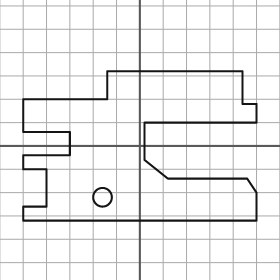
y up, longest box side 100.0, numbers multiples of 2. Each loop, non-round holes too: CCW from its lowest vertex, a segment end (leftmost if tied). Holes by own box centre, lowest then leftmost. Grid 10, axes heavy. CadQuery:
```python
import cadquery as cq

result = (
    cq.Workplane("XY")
    .moveTo(-50.0, -32.0)
    .lineTo(50.0, -32.0)
    .lineTo(50.0, -20.0)
    .lineTo(46.0, -14.0)
    .lineTo(12.0, -14.0)
    .lineTo(2.0, -6.0)
    .lineTo(2.0, 10.0)
    .lineTo(50.0, 10.0)
    .lineTo(50.0, 18.0)
    .lineTo(44.0, 18.0)
    .lineTo(44.0, 32.0)
    .lineTo(-14.0, 32.0)
    .lineTo(-14.0, 20.0)
    .lineTo(-50.0, 20.0)
    .lineTo(-50.0, 6.0)
    .lineTo(-30.0, 6.0)
    .lineTo(-30.0, -4.0)
    .lineTo(-50.0, -4.0)
    .lineTo(-50.0, -10.0)
    .lineTo(-40.0, -10.0)
    .lineTo(-40.0, -26.0)
    .lineTo(-50.0, -26.0)
    .close()
    .moveTo(-16.0, -22.0)
    .circle(4.0)
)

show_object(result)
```